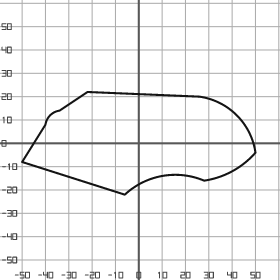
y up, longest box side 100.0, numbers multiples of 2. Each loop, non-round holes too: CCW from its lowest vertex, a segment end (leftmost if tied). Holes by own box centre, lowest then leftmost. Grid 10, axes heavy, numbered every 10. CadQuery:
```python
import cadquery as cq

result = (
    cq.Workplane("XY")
    .moveTo(-6.0, -22.0)
    .threePointArc((10.0, -14.0), (28.0, -16.0))
    .threePointArc((40.0, -12.0), (50.0, -4.0))
    .threePointArc((42.0, 12.0), (26.0, 20.0))
    .lineTo(-22.0, 22.0)
    .lineTo(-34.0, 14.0)
    .threePointArc((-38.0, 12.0), (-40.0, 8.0))
    .lineTo(-50.0, -8.0)
    .close()
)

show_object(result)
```